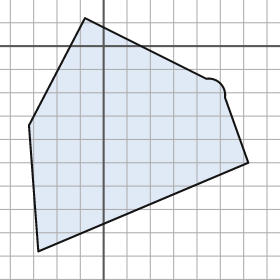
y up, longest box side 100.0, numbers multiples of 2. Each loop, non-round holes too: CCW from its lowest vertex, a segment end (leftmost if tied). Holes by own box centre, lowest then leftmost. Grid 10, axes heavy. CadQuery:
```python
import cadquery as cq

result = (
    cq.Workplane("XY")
    .moveTo(-28.0, -88.0)
    .lineTo(62.0, -50.0)
    .lineTo(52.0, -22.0)
    .threePointArc((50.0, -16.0), (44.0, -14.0))
    .lineTo(-8.0, 12.0)
    .lineTo(-32.0, -34.0)
    .close()
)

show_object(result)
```